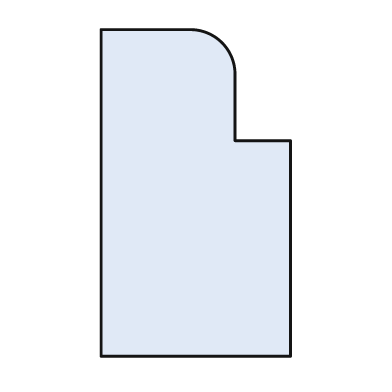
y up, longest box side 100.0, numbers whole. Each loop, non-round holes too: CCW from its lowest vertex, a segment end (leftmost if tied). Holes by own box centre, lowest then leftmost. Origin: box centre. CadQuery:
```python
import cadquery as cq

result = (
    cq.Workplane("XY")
    .moveTo(-29.0, -50.0)
    .lineTo(29.0, -50.0)
    .lineTo(29.0, 16.0)
    .lineTo(12.0, 16.0)
    .lineTo(12.0, 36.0)
    .threePointArc((8.0, 46.0), (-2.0, 50.0))
    .lineTo(-29.0, 50.0)
    .close()
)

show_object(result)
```